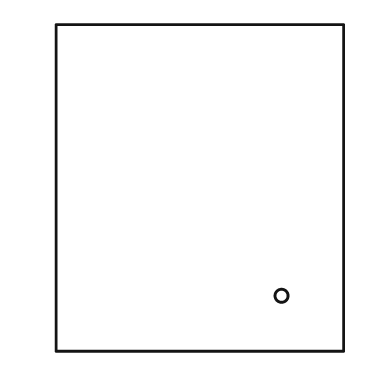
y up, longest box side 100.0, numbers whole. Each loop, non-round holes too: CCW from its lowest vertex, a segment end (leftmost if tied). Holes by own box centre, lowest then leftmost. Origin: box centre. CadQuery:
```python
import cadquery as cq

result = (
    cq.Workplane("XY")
    .moveTo(-44.0, -50.0)
    .lineTo(44.0, -50.0)
    .lineTo(44.0, 50.0)
    .lineTo(-44.0, 50.0)
    .close()
    .moveTo(25.0, -33.0)
    .circle(2.0)
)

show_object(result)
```